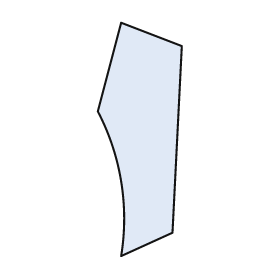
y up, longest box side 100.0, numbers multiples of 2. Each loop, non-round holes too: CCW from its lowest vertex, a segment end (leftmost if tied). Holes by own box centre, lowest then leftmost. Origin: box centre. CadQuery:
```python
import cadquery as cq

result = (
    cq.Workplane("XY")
    .moveTo(-8.0, -50.0)
    .lineTo(14.0, -40.0)
    .lineTo(18.0, 40.0)
    .lineTo(-8.0, 50.0)
    .lineTo(-18.0, 12.0)
    .threePointArc((-8.0, -18.0), (-8.0, -50.0))
    .close()
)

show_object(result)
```